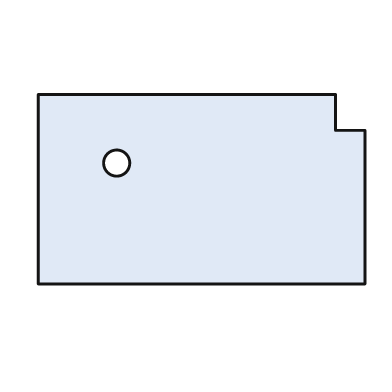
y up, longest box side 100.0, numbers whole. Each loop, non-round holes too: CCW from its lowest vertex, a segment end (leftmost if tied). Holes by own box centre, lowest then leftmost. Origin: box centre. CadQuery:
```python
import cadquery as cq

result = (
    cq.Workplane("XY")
    .moveTo(-50.0, -29.0)
    .lineTo(50.0, -29.0)
    .lineTo(50.0, 18.0)
    .lineTo(41.0, 18.0)
    .lineTo(41.0, 29.0)
    .lineTo(-50.0, 29.0)
    .close()
    .moveTo(-26.0, 8.0)
    .circle(4.0)
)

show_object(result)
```